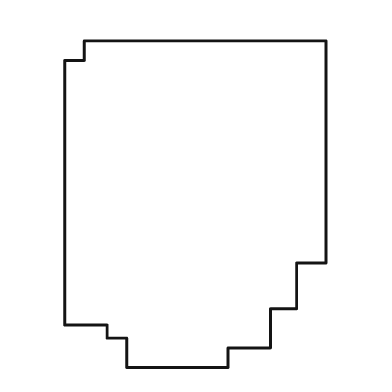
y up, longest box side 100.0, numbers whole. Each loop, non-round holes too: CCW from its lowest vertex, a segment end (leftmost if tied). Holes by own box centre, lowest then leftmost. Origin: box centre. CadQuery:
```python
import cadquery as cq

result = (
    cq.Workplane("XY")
    .moveTo(-21.0, -50.0)
    .lineTo(10.0, -50.0)
    .lineTo(10.0, -44.0)
    .lineTo(23.0, -44.0)
    .lineTo(23.0, -32.0)
    .lineTo(31.0, -32.0)
    .lineTo(31.0, -18.0)
    .lineTo(40.0, -18.0)
    .lineTo(40.0, 50.0)
    .lineTo(-34.0, 50.0)
    .lineTo(-34.0, 44.0)
    .lineTo(-40.0, 44.0)
    .lineTo(-40.0, -37.0)
    .lineTo(-27.0, -37.0)
    .lineTo(-27.0, -41.0)
    .lineTo(-21.0, -41.0)
    .close()
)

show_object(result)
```